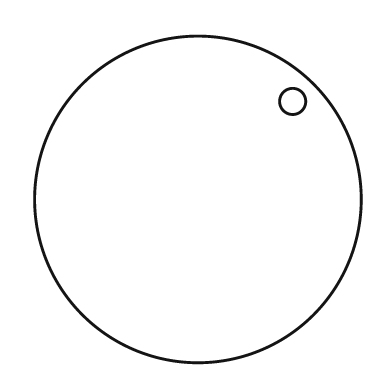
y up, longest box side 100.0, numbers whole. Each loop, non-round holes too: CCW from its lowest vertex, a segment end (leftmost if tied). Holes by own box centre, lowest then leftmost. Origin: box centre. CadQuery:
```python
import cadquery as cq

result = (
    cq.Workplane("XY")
    .moveTo(0.0, 0.0)
    .circle(50.0)
    .moveTo(29.0, 30.0)
    .circle(4.0)
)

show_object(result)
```